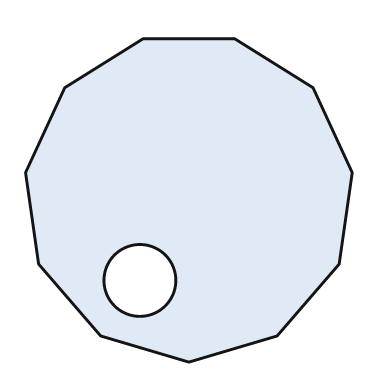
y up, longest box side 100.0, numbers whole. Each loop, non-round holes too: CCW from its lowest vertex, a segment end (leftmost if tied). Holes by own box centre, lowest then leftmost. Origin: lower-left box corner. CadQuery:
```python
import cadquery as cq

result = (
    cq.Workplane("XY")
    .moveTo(50.0, 0.0)
    .lineTo(77.0, 8.0)
    .lineTo(96.0, 30.0)
    .lineTo(100.0, 58.0)
    .lineTo(88.0, 84.0)
    .lineTo(64.0, 99.0)
    .lineTo(36.0, 99.0)
    .lineTo(12.0, 84.0)
    .lineTo(0.0, 58.0)
    .lineTo(4.0, 30.0)
    .lineTo(23.0, 8.0)
    .close()
    .moveTo(35.0, 25.0)
    .circle(11.0)
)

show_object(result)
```